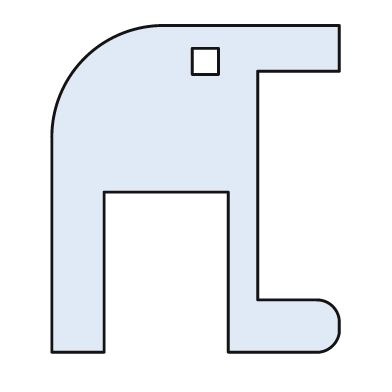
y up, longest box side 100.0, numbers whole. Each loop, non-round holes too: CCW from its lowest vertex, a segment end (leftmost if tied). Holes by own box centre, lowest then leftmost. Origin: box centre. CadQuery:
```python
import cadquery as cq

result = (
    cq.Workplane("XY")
    .moveTo(-44.0, -50.0)
    .lineTo(-28.0, -50.0)
    .lineTo(-28.0, -1.0)
    .lineTo(10.0, -1.0)
    .lineTo(10.0, -50.0)
    .lineTo(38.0, -50.0)
    .threePointArc((42.0, -48.0), (44.0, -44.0))
    .lineTo(44.0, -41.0)
    .threePointArc((42.0, -36.0), (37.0, -34.0))
    .lineTo(19.0, -34.0)
    .lineTo(19.0, 36.0)
    .lineTo(44.0, 36.0)
    .lineTo(44.0, 50.0)
    .lineTo(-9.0, 50.0)
    .threePointArc((-34.0, 40.0), (-44.0, 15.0))
    .close()
    .moveTo(-1.0, 35.0)
    .lineTo(7.0, 35.0)
    .lineTo(7.0, 43.0)
    .lineTo(-1.0, 43.0)
    .close()
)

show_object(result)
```